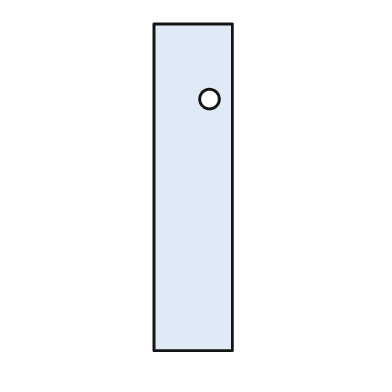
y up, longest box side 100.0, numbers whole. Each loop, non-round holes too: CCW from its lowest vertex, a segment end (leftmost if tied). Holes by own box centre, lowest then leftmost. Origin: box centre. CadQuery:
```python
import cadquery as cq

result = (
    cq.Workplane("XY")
    .moveTo(-12.0, -50.0)
    .lineTo(12.0, -50.0)
    .lineTo(12.0, 50.0)
    .lineTo(-12.0, 50.0)
    .close()
    .moveTo(5.0, 27.0)
    .circle(3.0)
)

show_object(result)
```